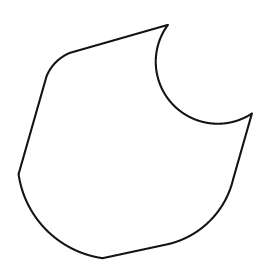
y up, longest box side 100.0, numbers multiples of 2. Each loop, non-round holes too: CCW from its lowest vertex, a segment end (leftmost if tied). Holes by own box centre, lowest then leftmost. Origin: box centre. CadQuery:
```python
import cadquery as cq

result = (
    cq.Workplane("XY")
    .moveTo(-14.0, -50.0)
    .lineTo(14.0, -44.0)
    .threePointArc((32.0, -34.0), (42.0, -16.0))
    .lineTo(50.0, 12.0)
    .threePointArc((16.0, 16.0), (14.0, 50.0))
    .lineTo(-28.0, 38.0)
    .threePointArc((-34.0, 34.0), (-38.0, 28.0))
    .lineTo(-50.0, -14.0)
    .threePointArc((-38.0, -38.0), (-14.0, -50.0))
    .close()
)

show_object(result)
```